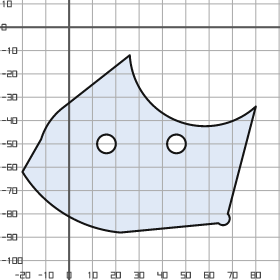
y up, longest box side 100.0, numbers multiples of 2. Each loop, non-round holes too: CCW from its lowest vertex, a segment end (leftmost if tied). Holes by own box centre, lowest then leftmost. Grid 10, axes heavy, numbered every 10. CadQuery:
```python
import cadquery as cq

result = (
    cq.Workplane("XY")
    .moveTo(22.0, -88.0)
    .lineTo(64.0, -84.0)
    .threePointArc((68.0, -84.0), (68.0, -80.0))
    .lineTo(80.0, -34.0)
    .threePointArc((46.0, -40.0), (26.0, -12.0))
    .lineTo(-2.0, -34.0)
    .threePointArc((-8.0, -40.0), (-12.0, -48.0))
    .lineTo(-20.0, -62.0)
    .threePointArc((-2.0, -80.0), (22.0, -88.0))
    .close()
    .moveTo(16.0, -50.0)
    .circle(4.0)
    .moveTo(46.0, -50.0)
    .circle(4.0)
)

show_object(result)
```